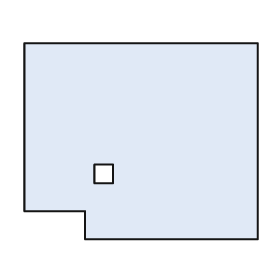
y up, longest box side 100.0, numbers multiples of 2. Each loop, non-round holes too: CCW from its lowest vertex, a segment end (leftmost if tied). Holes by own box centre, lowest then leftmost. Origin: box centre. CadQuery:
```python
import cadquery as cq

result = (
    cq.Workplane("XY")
    .moveTo(-24.0, -42.0)
    .lineTo(50.0, -42.0)
    .lineTo(50.0, 42.0)
    .lineTo(-50.0, 42.0)
    .lineTo(-50.0, -30.0)
    .lineTo(-24.0, -30.0)
    .close()
    .moveTo(-20.0, -18.0)
    .lineTo(-12.0, -18.0)
    .lineTo(-12.0, -10.0)
    .lineTo(-20.0, -10.0)
    .close()
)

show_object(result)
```